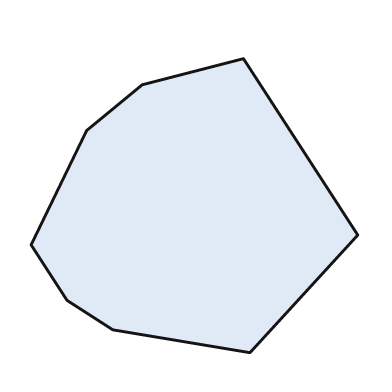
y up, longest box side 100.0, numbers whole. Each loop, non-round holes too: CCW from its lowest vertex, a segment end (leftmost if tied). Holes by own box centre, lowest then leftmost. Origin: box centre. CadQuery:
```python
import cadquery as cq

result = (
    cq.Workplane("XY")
    .moveTo(17.0, -45.0)
    .lineTo(50.0, -9.0)
    .lineTo(15.0, 45.0)
    .lineTo(-16.0, 37.0)
    .lineTo(-33.0, 23.0)
    .lineTo(-50.0, -12.0)
    .lineTo(-39.0, -29.0)
    .lineTo(-25.0, -38.0)
    .close()
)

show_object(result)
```